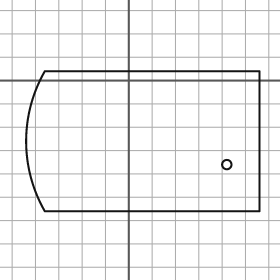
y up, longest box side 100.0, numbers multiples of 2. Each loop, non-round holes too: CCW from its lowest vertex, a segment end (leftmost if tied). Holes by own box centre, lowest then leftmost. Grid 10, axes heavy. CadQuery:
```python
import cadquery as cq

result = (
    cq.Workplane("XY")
    .moveTo(-36.0, -56.0)
    .lineTo(56.0, -56.0)
    .lineTo(56.0, 4.0)
    .lineTo(-36.0, 4.0)
    .threePointArc((-44.0, -26.0), (-36.0, -56.0))
    .close()
    .moveTo(42.0, -36.0)
    .circle(2.0)
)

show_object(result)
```